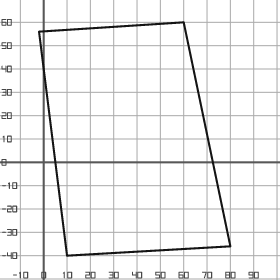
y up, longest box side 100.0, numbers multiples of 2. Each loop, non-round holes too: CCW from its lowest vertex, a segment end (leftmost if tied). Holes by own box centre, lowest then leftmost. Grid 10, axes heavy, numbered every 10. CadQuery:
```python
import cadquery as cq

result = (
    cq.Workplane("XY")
    .moveTo(10.0, -40.0)
    .lineTo(80.0, -36.0)
    .lineTo(60.0, 60.0)
    .lineTo(-2.0, 56.0)
    .close()
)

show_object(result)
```